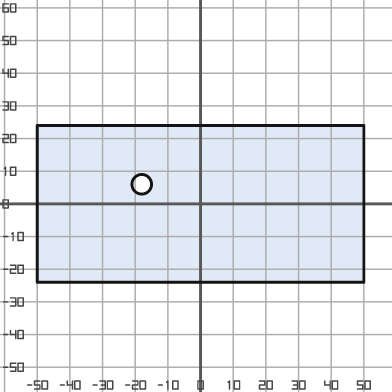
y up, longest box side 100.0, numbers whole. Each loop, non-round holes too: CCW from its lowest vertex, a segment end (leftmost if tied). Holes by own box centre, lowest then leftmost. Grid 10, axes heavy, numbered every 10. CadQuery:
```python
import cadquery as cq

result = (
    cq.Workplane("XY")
    .moveTo(-50.0, -24.0)
    .lineTo(50.0, -24.0)
    .lineTo(50.0, 24.0)
    .lineTo(-50.0, 24.0)
    .close()
    .moveTo(-18.0, 6.0)
    .circle(3.0)
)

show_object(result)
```